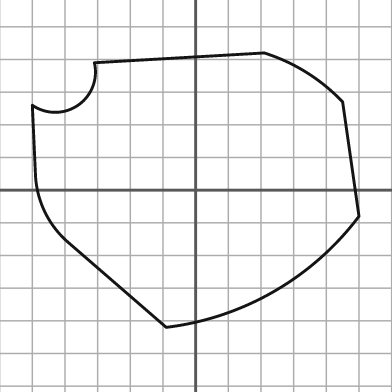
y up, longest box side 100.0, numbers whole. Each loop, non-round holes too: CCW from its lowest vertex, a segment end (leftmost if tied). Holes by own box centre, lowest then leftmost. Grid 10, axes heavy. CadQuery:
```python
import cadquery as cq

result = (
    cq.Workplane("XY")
    .moveTo(-9.0, -42.0)
    .threePointArc((24.0, -31.0), (50.0, -8.0))
    .lineTo(45.0, 27.0)
    .threePointArc((34.0, 36.0), (21.0, 42.0))
    .lineTo(-31.0, 39.0)
    .threePointArc((-36.0, 26.0), (-50.0, 26.0))
    .lineTo(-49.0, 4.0)
    .threePointArc((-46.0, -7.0), (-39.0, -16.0))
    .close()
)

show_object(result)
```